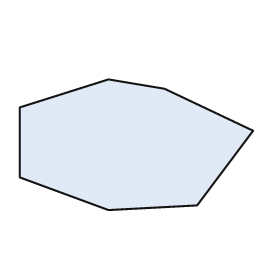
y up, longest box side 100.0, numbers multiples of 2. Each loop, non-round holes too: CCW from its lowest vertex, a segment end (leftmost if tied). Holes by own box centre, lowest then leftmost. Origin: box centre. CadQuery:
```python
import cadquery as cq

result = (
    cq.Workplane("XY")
    .moveTo(-12.0, -28.0)
    .lineTo(26.0, -26.0)
    .lineTo(50.0, 6.0)
    .lineTo(12.0, 24.0)
    .lineTo(-12.0, 28.0)
    .lineTo(-50.0, 16.0)
    .lineTo(-50.0, -14.0)
    .close()
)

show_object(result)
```